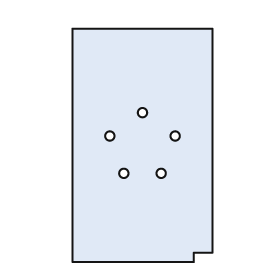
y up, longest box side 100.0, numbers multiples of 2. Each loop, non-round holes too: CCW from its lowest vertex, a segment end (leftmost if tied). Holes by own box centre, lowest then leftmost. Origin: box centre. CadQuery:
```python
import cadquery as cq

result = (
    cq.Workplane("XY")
    .moveTo(-30.0, -50.0)
    .lineTo(22.0, -50.0)
    .lineTo(22.0, -46.0)
    .lineTo(30.0, -46.0)
    .lineTo(30.0, 50.0)
    .lineTo(-30.0, 50.0)
    .close()
    .moveTo(-8.0, -12.0)
    .circle(2.0)
    .moveTo(8.0, -12.0)
    .circle(2.0)
    .moveTo(-14.0, 4.0)
    .circle(2.0)
    .moveTo(14.0, 4.0)
    .circle(2.0)
    .moveTo(0.0, 14.0)
    .circle(2.0)
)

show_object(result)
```